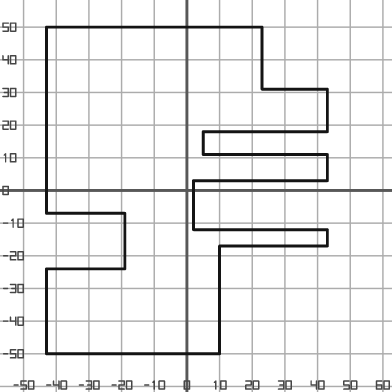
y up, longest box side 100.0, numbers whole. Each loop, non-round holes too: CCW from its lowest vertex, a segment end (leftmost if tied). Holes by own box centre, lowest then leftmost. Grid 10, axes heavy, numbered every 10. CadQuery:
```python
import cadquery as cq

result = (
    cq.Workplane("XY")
    .moveTo(-43.0, -50.0)
    .lineTo(10.0, -50.0)
    .lineTo(10.0, -17.0)
    .lineTo(43.0, -17.0)
    .lineTo(43.0, -12.0)
    .lineTo(2.0, -12.0)
    .lineTo(2.0, 3.0)
    .lineTo(43.0, 3.0)
    .lineTo(43.0, 11.0)
    .lineTo(5.0, 11.0)
    .lineTo(5.0, 18.0)
    .lineTo(43.0, 18.0)
    .lineTo(43.0, 31.0)
    .lineTo(23.0, 31.0)
    .lineTo(23.0, 50.0)
    .lineTo(-43.0, 50.0)
    .lineTo(-43.0, -7.0)
    .lineTo(-19.0, -7.0)
    .lineTo(-19.0, -24.0)
    .lineTo(-43.0, -24.0)
    .close()
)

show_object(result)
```